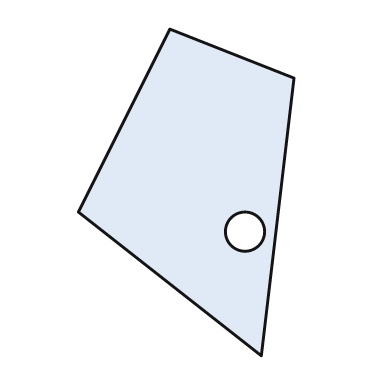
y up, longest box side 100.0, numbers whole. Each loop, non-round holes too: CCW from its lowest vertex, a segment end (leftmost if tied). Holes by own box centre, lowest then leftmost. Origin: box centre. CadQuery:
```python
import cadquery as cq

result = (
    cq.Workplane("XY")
    .moveTo(23.0, -50.0)
    .lineTo(33.0, 35.0)
    .lineTo(-5.0, 50.0)
    .lineTo(-33.0, -6.0)
    .close()
    .moveTo(18.0, -12.0)
    .circle(6.0)
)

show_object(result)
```